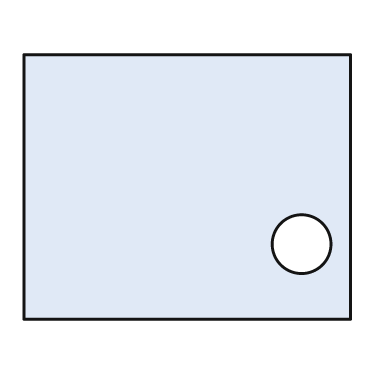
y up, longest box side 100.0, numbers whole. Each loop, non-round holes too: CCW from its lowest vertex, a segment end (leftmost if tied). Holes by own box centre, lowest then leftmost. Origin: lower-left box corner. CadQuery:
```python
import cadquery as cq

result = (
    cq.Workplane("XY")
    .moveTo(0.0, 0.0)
    .lineTo(100.0, 0.0)
    .lineTo(100.0, 81.0)
    .lineTo(0.0, 81.0)
    .close()
    .moveTo(85.0, 23.0)
    .circle(9.0)
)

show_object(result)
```